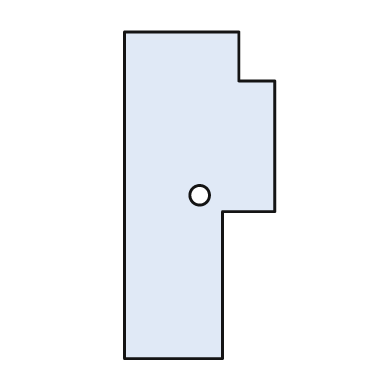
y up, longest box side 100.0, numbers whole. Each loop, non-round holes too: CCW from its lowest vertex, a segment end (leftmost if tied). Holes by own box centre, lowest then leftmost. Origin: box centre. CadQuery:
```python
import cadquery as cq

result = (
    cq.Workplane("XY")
    .moveTo(-23.0, -50.0)
    .lineTo(7.0, -50.0)
    .lineTo(7.0, -5.0)
    .lineTo(23.0, -5.0)
    .lineTo(23.0, 35.0)
    .lineTo(12.0, 35.0)
    .lineTo(12.0, 50.0)
    .lineTo(-23.0, 50.0)
    .close()
    .moveTo(0.0, 0.0)
    .circle(3.0)
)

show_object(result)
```